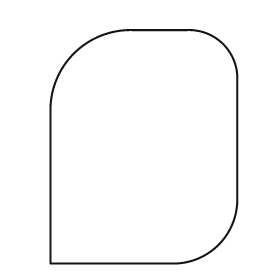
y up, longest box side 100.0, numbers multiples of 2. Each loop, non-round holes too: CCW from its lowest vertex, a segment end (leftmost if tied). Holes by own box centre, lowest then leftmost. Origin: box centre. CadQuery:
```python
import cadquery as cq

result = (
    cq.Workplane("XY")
    .moveTo(-40.0, -50.0)
    .lineTo(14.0, -50.0)
    .threePointArc((32.0, -42.0), (40.0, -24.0))
    .lineTo(40.0, 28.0)
    .threePointArc((34.0, 44.0), (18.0, 50.0))
    .lineTo(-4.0, 50.0)
    .threePointArc((-30.0, 40.0), (-40.0, 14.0))
    .close()
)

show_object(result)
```